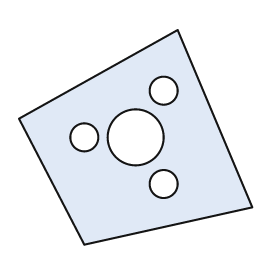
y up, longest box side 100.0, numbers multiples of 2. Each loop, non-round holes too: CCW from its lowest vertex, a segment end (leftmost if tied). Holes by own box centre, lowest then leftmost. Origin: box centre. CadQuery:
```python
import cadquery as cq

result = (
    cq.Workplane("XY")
    .moveTo(-22.0, -46.0)
    .lineTo(50.0, -30.0)
    .lineTo(18.0, 46.0)
    .lineTo(-50.0, 8.0)
    .close()
    .moveTo(12.0, -20.0)
    .circle(6.0)
    .moveTo(-22.0, 0.0)
    .circle(6.0)
    .moveTo(0.0, 0.0)
    .circle(12.0)
    .moveTo(12.0, 20.0)
    .circle(6.0)
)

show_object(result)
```